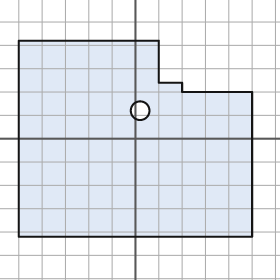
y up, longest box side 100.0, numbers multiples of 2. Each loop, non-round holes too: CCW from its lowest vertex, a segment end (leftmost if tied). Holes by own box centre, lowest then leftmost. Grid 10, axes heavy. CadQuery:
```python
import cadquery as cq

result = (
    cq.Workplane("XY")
    .moveTo(-50.0, -42.0)
    .lineTo(50.0, -42.0)
    .lineTo(50.0, 20.0)
    .lineTo(20.0, 20.0)
    .lineTo(20.0, 24.0)
    .lineTo(10.0, 24.0)
    .lineTo(10.0, 42.0)
    .lineTo(-50.0, 42.0)
    .close()
    .moveTo(2.0, 12.0)
    .circle(4.0)
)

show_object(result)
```